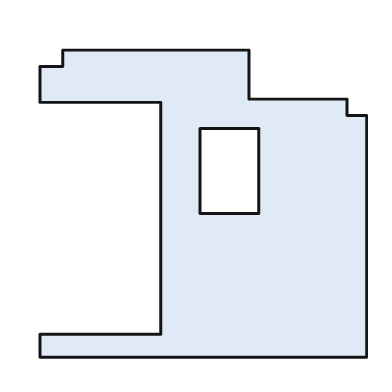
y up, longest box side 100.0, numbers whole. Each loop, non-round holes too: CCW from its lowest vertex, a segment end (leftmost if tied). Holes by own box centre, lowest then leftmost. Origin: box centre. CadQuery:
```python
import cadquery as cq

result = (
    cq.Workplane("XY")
    .moveTo(-50.0, -47.0)
    .lineTo(50.0, -47.0)
    .lineTo(50.0, 27.0)
    .lineTo(44.0, 27.0)
    .lineTo(44.0, 32.0)
    .lineTo(14.0, 32.0)
    .lineTo(14.0, 47.0)
    .lineTo(-43.0, 47.0)
    .lineTo(-43.0, 42.0)
    .lineTo(-50.0, 42.0)
    .lineTo(-50.0, 31.0)
    .lineTo(-13.0, 31.0)
    .lineTo(-13.0, -40.0)
    .lineTo(-50.0, -40.0)
    .close()
    .moveTo(-1.0, -3.0)
    .lineTo(17.0, -3.0)
    .lineTo(17.0, 23.0)
    .lineTo(-1.0, 23.0)
    .close()
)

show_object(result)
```